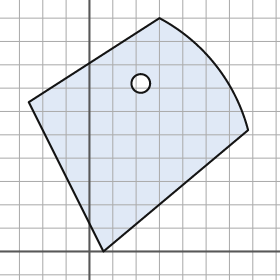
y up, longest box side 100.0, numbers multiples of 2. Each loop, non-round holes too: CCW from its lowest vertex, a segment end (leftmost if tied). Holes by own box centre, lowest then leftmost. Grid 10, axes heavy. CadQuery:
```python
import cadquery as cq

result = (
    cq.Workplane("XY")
    .moveTo(6.0, 0.0)
    .lineTo(68.0, 52.0)
    .threePointArc((54.0, 80.0), (30.0, 100.0))
    .lineTo(-26.0, 64.0)
    .close()
    .moveTo(22.0, 72.0)
    .circle(4.0)
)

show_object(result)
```